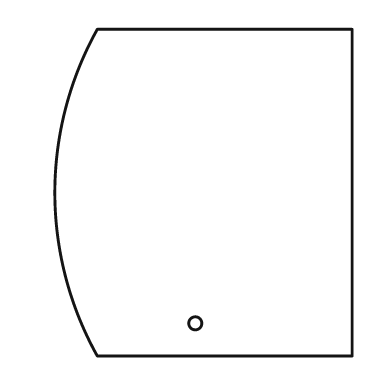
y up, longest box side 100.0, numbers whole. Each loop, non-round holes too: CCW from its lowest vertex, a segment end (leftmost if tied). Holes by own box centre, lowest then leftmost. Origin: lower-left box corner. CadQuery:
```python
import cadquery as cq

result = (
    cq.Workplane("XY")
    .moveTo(13.0, 0.0)
    .lineTo(91.0, 0.0)
    .lineTo(91.0, 100.0)
    .lineTo(13.0, 100.0)
    .threePointArc((0.0, 50.0), (13.0, 0.0))
    .close()
    .moveTo(43.0, 10.0)
    .circle(2.0)
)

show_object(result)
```